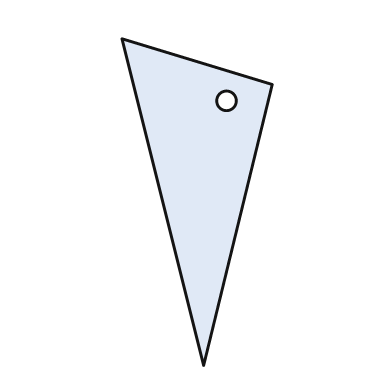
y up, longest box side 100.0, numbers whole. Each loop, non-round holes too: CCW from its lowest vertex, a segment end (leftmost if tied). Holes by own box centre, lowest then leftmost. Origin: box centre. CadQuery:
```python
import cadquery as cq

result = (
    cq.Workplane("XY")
    .moveTo(2.0, -50.0)
    .lineTo(23.0, 36.0)
    .lineTo(-23.0, 50.0)
    .close()
    .moveTo(9.0, 31.0)
    .circle(3.0)
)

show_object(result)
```